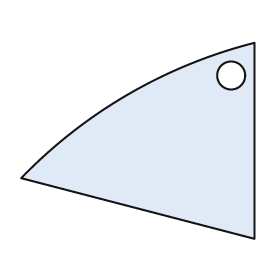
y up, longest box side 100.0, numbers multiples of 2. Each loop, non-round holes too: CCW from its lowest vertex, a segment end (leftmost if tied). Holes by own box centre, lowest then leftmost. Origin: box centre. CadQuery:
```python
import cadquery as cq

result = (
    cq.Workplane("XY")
    .moveTo(50.0, -42.0)
    .lineTo(50.0, 42.0)
    .threePointArc((-4.0, 20.0), (-50.0, -16.0))
    .close()
    .moveTo(40.0, 28.0)
    .circle(6.0)
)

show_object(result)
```